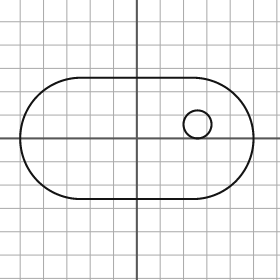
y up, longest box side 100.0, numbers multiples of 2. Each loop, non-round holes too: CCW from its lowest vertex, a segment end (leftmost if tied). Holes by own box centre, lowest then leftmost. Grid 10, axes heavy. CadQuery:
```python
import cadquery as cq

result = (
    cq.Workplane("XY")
    .moveTo(-24.0, -26.0)
    .lineTo(24.0, -26.0)
    .threePointArc((50.0, 0.0), (24.0, 26.0))
    .lineTo(-24.0, 26.0)
    .threePointArc((-50.0, 0.0), (-24.0, -26.0))
    .close()
    .moveTo(26.0, 6.0)
    .circle(6.0)
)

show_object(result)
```